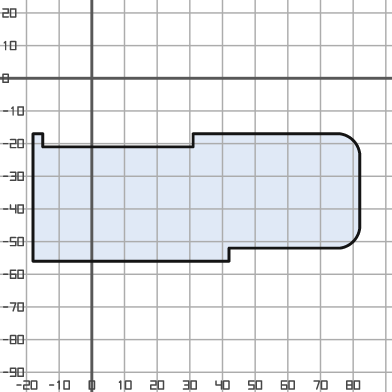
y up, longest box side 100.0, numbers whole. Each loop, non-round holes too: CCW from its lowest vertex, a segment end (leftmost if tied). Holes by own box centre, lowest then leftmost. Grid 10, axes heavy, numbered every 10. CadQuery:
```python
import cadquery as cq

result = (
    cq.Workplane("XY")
    .moveTo(-18.0, -56.0)
    .lineTo(42.0, -56.0)
    .lineTo(42.0, -52.0)
    .lineTo(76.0, -52.0)
    .threePointArc((80.0, -50.0), (82.0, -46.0))
    .lineTo(82.0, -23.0)
    .threePointArc((80.0, -19.0), (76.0, -17.0))
    .lineTo(31.0, -17.0)
    .lineTo(31.0, -21.0)
    .lineTo(-15.0, -21.0)
    .lineTo(-15.0, -17.0)
    .lineTo(-18.0, -17.0)
    .close()
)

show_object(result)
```